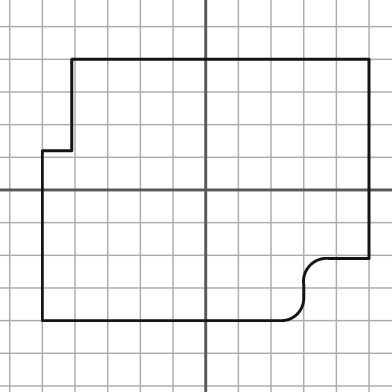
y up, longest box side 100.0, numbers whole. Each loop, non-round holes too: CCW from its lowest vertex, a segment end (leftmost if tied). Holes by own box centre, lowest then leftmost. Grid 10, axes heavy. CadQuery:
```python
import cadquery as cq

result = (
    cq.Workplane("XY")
    .moveTo(-50.0, -40.0)
    .lineTo(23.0, -40.0)
    .threePointArc((28.0, -38.0), (30.0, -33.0))
    .lineTo(30.0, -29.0)
    .threePointArc((32.0, -23.0), (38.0, -21.0))
    .lineTo(50.0, -21.0)
    .lineTo(50.0, 40.0)
    .lineTo(-41.0, 40.0)
    .lineTo(-41.0, 12.0)
    .lineTo(-50.0, 12.0)
    .close()
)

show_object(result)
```